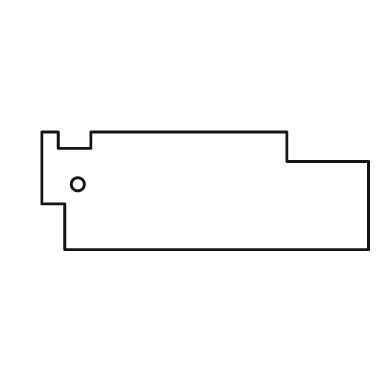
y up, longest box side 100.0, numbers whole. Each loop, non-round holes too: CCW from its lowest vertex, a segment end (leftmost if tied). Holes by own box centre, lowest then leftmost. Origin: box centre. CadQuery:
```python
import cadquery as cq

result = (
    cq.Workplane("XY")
    .moveTo(-43.0, -18.0)
    .lineTo(50.0, -18.0)
    .lineTo(50.0, 9.0)
    .lineTo(25.0, 9.0)
    .lineTo(25.0, 18.0)
    .lineTo(-35.0, 18.0)
    .lineTo(-35.0, 13.0)
    .lineTo(-45.0, 13.0)
    .lineTo(-45.0, 18.0)
    .lineTo(-50.0, 18.0)
    .lineTo(-50.0, -4.0)
    .lineTo(-43.0, -4.0)
    .close()
    .moveTo(-39.0, 2.0)
    .circle(2.0)
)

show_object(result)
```